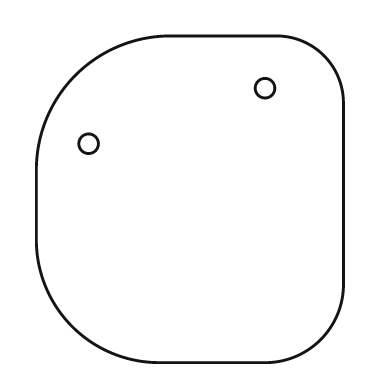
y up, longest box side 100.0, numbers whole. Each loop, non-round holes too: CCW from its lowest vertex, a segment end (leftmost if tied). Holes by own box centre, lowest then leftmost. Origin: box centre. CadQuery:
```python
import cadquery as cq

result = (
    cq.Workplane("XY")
    .moveTo(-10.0, -50.0)
    .lineTo(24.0, -50.0)
    .threePointArc((40.0, -43.0), (47.0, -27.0))
    .lineTo(47.0, 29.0)
    .threePointArc((41.0, 44.0), (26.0, 50.0))
    .lineTo(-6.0, 50.0)
    .threePointArc((-35.0, 38.0), (-47.0, 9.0))
    .lineTo(-47.0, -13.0)
    .threePointArc((-36.0, -39.0), (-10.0, -50.0))
    .close()
    .moveTo(-31.0, 17.0)
    .circle(3.0)
    .moveTo(23.0, 34.0)
    .circle(3.0)
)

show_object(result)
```